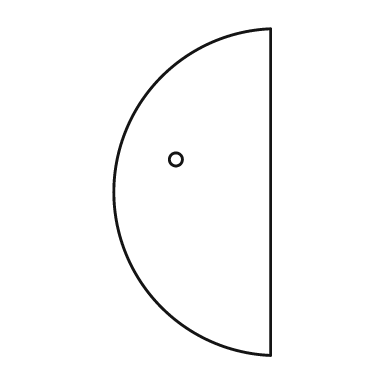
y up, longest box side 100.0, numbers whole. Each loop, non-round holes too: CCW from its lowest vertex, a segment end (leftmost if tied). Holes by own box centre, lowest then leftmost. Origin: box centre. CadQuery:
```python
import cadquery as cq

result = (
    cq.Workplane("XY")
    .moveTo(24.0, -50.0)
    .lineTo(24.0, 50.0)
    .threePointArc((-24.0, 0.0), (24.0, -50.0))
    .close()
    .moveTo(-5.0, 10.0)
    .circle(2.0)
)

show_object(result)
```